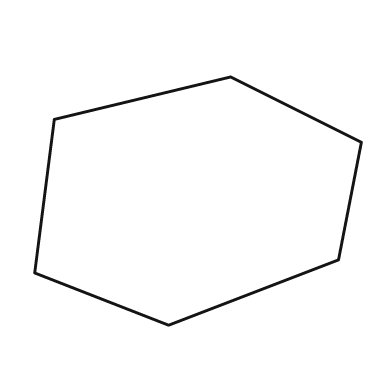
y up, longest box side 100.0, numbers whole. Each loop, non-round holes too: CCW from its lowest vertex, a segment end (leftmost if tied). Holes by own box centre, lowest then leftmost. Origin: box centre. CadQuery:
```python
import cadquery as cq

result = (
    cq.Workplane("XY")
    .moveTo(-9.0, -38.0)
    .lineTo(43.0, -18.0)
    .lineTo(50.0, 18.0)
    .lineTo(10.0, 38.0)
    .lineTo(-44.0, 25.0)
    .lineTo(-50.0, -22.0)
    .close()
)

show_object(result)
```